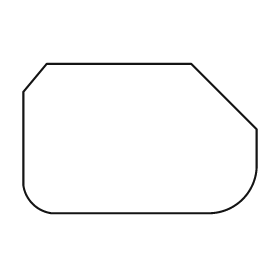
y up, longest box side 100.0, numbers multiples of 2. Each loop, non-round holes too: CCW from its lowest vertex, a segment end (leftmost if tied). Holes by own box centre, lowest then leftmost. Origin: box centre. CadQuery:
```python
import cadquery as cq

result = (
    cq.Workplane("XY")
    .moveTo(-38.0, -32.0)
    .lineTo(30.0, -32.0)
    .threePointArc((44.0, -26.0), (50.0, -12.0))
    .lineTo(50.0, 4.0)
    .lineTo(22.0, 32.0)
    .lineTo(-40.0, 32.0)
    .lineTo(-50.0, 20.0)
    .lineTo(-50.0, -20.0)
    .threePointArc((-46.0, -28.0), (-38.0, -32.0))
    .close()
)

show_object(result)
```